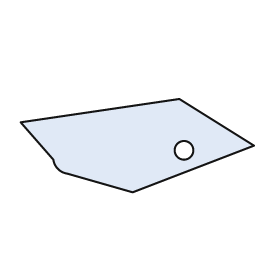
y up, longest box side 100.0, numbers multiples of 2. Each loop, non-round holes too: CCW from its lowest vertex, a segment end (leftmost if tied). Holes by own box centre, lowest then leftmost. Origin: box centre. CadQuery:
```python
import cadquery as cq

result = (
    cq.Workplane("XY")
    .moveTo(-2.0, -20.0)
    .lineTo(50.0, 0.0)
    .lineTo(18.0, 20.0)
    .lineTo(-50.0, 10.0)
    .lineTo(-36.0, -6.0)
    .threePointArc((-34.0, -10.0), (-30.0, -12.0))
    .close()
    .moveTo(20.0, -2.0)
    .circle(4.0)
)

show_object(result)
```